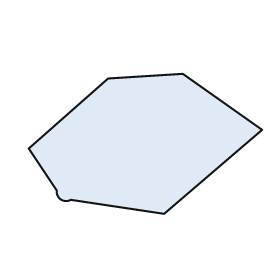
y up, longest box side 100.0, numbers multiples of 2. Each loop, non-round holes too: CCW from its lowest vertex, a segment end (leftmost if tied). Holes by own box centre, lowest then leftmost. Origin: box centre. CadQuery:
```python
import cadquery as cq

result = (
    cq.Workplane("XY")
    .moveTo(8.0, -30.0)
    .lineTo(50.0, 6.0)
    .lineTo(16.0, 30.0)
    .lineTo(-16.0, 28.0)
    .lineTo(-50.0, -2.0)
    .lineTo(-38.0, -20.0)
    .threePointArc((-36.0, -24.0), (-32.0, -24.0))
    .close()
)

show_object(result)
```